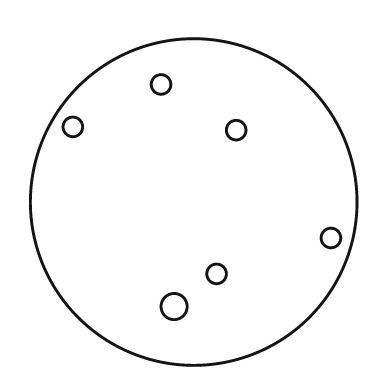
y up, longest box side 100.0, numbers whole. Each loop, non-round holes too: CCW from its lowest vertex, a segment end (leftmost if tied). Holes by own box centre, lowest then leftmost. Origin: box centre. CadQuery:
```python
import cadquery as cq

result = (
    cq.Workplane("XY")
    .moveTo(0.0, 0.0)
    .circle(50.0)
    .moveTo(-6.0, -32.0)
    .circle(4.0)
    .moveTo(7.0, -22.0)
    .circle(3.0)
    .moveTo(42.0, -11.0)
    .circle(3.0)
    .moveTo(13.0, 22.0)
    .circle(3.0)
    .moveTo(-37.0, 23.0)
    .circle(3.0)
    .moveTo(-10.0, 36.0)
    .circle(3.0)
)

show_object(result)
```